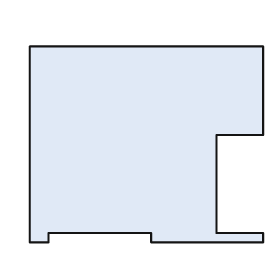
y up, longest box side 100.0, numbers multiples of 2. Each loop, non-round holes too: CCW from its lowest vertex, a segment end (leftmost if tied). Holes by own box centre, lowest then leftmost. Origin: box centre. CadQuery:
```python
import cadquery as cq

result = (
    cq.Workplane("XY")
    .moveTo(-50.0, -42.0)
    .lineTo(-42.0, -42.0)
    .lineTo(-42.0, -38.0)
    .lineTo(2.0, -38.0)
    .lineTo(2.0, -42.0)
    .lineTo(50.0, -42.0)
    .lineTo(50.0, -38.0)
    .lineTo(30.0, -38.0)
    .lineTo(30.0, 4.0)
    .lineTo(50.0, 4.0)
    .lineTo(50.0, 42.0)
    .lineTo(-50.0, 42.0)
    .close()
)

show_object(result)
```